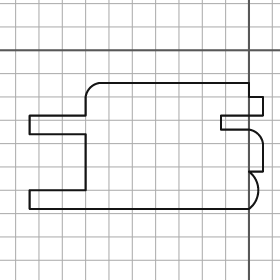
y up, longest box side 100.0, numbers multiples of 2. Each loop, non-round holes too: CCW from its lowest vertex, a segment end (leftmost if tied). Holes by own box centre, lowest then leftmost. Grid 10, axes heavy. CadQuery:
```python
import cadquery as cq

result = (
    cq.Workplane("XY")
    .moveTo(-94.0, -68.0)
    .lineTo(0.0, -68.0)
    .threePointArc((4.0, -60.0), (0.0, -52.0))
    .lineTo(6.0, -52.0)
    .lineTo(6.0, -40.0)
    .threePointArc((4.0, -36.0), (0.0, -34.0))
    .lineTo(-12.0, -34.0)
    .lineTo(-12.0, -28.0)
    .lineTo(6.0, -28.0)
    .lineTo(6.0, -20.0)
    .lineTo(0.0, -20.0)
    .lineTo(0.0, -14.0)
    .lineTo(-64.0, -14.0)
    .threePointArc((-68.0, -16.0), (-70.0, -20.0))
    .lineTo(-70.0, -28.0)
    .lineTo(-94.0, -28.0)
    .lineTo(-94.0, -36.0)
    .lineTo(-70.0, -36.0)
    .lineTo(-70.0, -60.0)
    .lineTo(-94.0, -60.0)
    .close()
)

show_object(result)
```